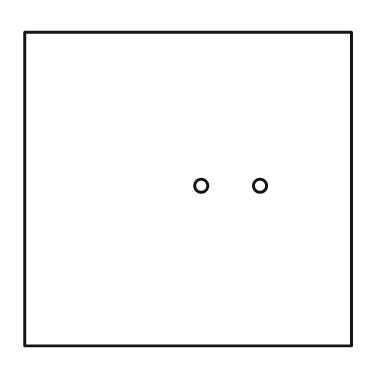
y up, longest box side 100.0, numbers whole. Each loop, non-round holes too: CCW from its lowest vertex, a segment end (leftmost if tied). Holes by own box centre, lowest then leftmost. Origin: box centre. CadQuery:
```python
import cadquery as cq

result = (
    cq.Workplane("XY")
    .moveTo(-50.0, -48.0)
    .lineTo(50.0, -48.0)
    .lineTo(50.0, 48.0)
    .lineTo(-50.0, 48.0)
    .close()
    .moveTo(4.0, 1.0)
    .circle(2.0)
    .moveTo(22.0, 1.0)
    .circle(2.0)
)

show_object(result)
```